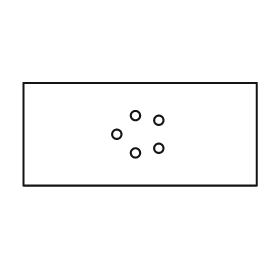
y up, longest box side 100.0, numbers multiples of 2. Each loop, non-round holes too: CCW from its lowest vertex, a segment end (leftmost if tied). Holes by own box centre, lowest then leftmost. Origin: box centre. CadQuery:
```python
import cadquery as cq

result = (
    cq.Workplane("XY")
    .moveTo(-50.0, -22.0)
    .lineTo(50.0, -22.0)
    .lineTo(50.0, 22.0)
    .lineTo(-50.0, 22.0)
    .close()
    .moveTo(-2.0, -8.0)
    .circle(2.0)
    .moveTo(8.0, -6.0)
    .circle(2.0)
    .moveTo(-10.0, 0.0)
    .circle(2.0)
    .moveTo(8.0, 6.0)
    .circle(2.0)
    .moveTo(-2.0, 8.0)
    .circle(2.0)
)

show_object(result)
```